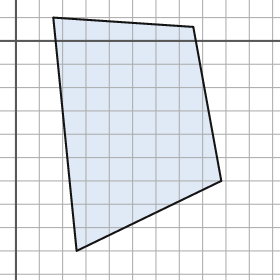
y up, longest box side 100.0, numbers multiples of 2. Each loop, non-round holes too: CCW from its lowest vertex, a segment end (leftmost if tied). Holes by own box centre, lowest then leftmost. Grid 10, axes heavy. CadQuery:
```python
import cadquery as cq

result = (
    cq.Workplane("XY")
    .moveTo(26.0, -90.0)
    .lineTo(88.0, -60.0)
    .lineTo(76.0, 6.0)
    .lineTo(16.0, 10.0)
    .close()
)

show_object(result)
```